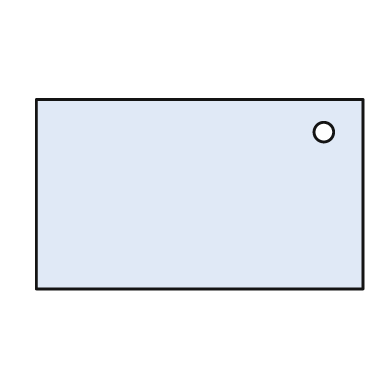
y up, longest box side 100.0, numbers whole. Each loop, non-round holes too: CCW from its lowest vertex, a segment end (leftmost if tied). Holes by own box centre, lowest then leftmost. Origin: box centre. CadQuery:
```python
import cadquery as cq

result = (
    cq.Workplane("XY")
    .moveTo(-50.0, -29.0)
    .lineTo(50.0, -29.0)
    .lineTo(50.0, 29.0)
    .lineTo(-50.0, 29.0)
    .close()
    .moveTo(38.0, 19.0)
    .circle(3.0)
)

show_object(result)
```